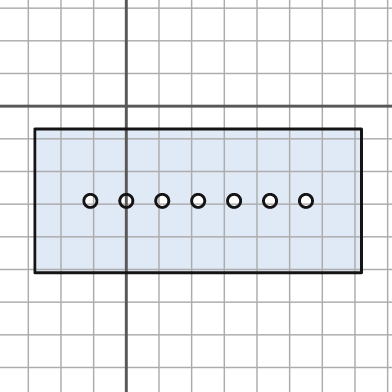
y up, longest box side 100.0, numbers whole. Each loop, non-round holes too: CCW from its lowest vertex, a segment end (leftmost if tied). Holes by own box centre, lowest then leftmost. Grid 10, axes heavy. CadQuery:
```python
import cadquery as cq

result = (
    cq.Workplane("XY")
    .moveTo(-28.0, -51.0)
    .lineTo(72.0, -51.0)
    .lineTo(72.0, -7.0)
    .lineTo(-28.0, -7.0)
    .close()
    .moveTo(-11.0, -29.0)
    .circle(2.0)
    .moveTo(0.0, -29.0)
    .circle(2.0)
    .moveTo(11.0, -29.0)
    .circle(2.0)
    .moveTo(22.0, -29.0)
    .circle(2.0)
    .moveTo(33.0, -29.0)
    .circle(2.0)
    .moveTo(44.0, -29.0)
    .circle(2.0)
    .moveTo(55.0, -29.0)
    .circle(2.0)
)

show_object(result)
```